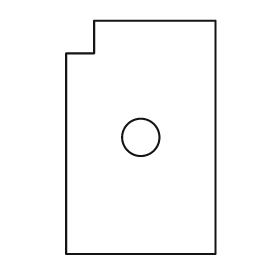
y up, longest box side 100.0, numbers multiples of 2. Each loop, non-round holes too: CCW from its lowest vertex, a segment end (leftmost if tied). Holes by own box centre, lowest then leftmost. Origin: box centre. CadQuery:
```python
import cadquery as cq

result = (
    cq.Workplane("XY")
    .moveTo(-32.0, -50.0)
    .lineTo(32.0, -50.0)
    .lineTo(32.0, 50.0)
    .lineTo(-20.0, 50.0)
    .lineTo(-20.0, 36.0)
    .lineTo(-32.0, 36.0)
    .close()
    .moveTo(0.0, 0.0)
    .circle(8.0)
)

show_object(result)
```